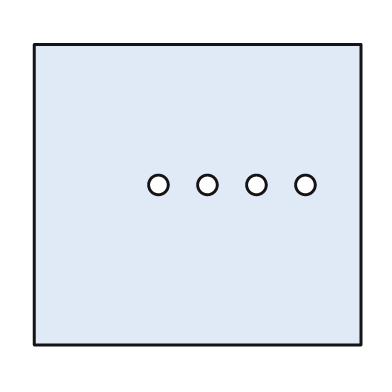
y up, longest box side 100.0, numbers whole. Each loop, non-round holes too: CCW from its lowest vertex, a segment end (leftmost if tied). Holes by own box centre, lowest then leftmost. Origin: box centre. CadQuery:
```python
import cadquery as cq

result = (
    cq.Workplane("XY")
    .moveTo(-50.0, -46.0)
    .lineTo(50.0, -46.0)
    .lineTo(50.0, 46.0)
    .lineTo(-50.0, 46.0)
    .close()
    .moveTo(-12.0, 3.0)
    .circle(3.0)
    .moveTo(3.0, 3.0)
    .circle(3.0)
    .moveTo(18.0, 3.0)
    .circle(3.0)
    .moveTo(33.0, 3.0)
    .circle(3.0)
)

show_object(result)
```